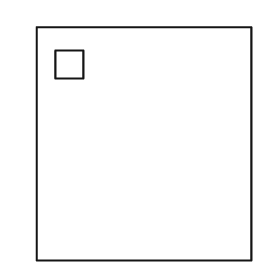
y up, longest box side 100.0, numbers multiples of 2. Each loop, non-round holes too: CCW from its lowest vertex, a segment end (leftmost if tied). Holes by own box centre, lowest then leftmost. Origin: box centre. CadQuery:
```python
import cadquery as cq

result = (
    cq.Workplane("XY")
    .moveTo(-46.0, -50.0)
    .lineTo(46.0, -50.0)
    .lineTo(46.0, 50.0)
    .lineTo(-46.0, 50.0)
    .close()
    .moveTo(-38.0, 28.0)
    .lineTo(-26.0, 28.0)
    .lineTo(-26.0, 40.0)
    .lineTo(-38.0, 40.0)
    .close()
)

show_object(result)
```